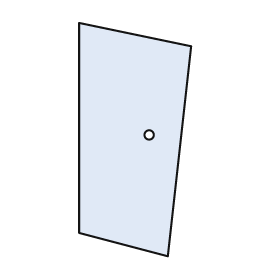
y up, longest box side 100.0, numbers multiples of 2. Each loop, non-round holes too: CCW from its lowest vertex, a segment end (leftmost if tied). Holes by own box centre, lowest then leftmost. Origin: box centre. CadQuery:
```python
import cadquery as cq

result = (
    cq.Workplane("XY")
    .moveTo(14.0, -50.0)
    .lineTo(24.0, 40.0)
    .lineTo(-24.0, 50.0)
    .lineTo(-24.0, -40.0)
    .close()
    .moveTo(6.0, 2.0)
    .circle(2.0)
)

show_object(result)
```